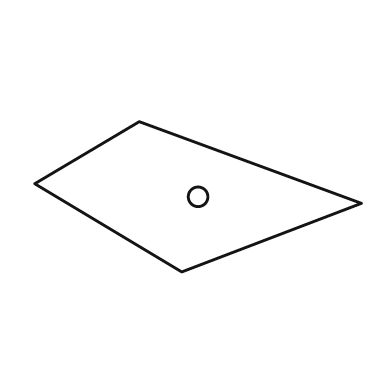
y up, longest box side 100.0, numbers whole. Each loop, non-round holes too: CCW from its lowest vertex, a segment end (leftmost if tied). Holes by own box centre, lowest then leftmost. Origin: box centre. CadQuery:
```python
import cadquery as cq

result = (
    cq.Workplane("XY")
    .moveTo(-5.0, -23.0)
    .lineTo(50.0, -2.0)
    .lineTo(-18.0, 23.0)
    .lineTo(-50.0, 4.0)
    .close()
    .moveTo(0.0, 0.0)
    .circle(3.0)
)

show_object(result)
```